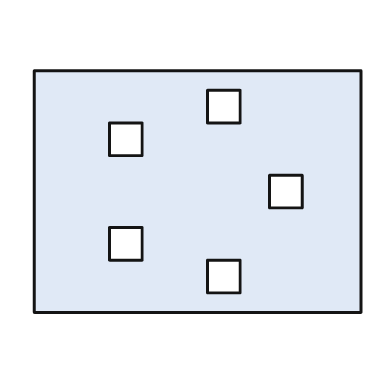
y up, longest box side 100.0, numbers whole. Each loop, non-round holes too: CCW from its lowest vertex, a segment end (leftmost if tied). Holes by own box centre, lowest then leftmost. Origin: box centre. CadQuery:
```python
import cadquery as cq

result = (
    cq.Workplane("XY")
    .moveTo(-50.0, -37.0)
    .lineTo(50.0, -37.0)
    .lineTo(50.0, 37.0)
    .lineTo(-50.0, 37.0)
    .close()
    .moveTo(3.0, -31.0)
    .lineTo(13.0, -31.0)
    .lineTo(13.0, -21.0)
    .lineTo(3.0, -21.0)
    .close()
    .moveTo(-27.0, -21.0)
    .lineTo(-17.0, -21.0)
    .lineTo(-17.0, -11.0)
    .lineTo(-27.0, -11.0)
    .close()
    .moveTo(22.0, -5.0)
    .lineTo(32.0, -5.0)
    .lineTo(32.0, 5.0)
    .lineTo(22.0, 5.0)
    .close()
    .moveTo(-27.0, 11.0)
    .lineTo(-17.0, 11.0)
    .lineTo(-17.0, 21.0)
    .lineTo(-27.0, 21.0)
    .close()
    .moveTo(3.0, 21.0)
    .lineTo(13.0, 21.0)
    .lineTo(13.0, 31.0)
    .lineTo(3.0, 31.0)
    .close()
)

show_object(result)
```